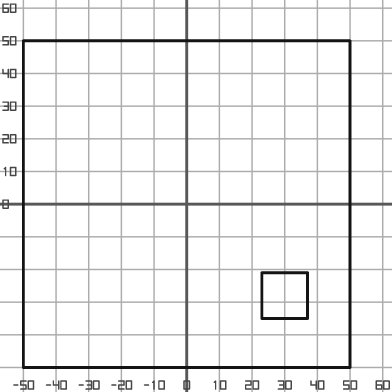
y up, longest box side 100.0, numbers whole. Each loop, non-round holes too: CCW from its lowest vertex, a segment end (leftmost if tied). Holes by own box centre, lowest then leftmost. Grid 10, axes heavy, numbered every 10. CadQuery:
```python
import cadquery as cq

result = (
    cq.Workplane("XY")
    .moveTo(-50.0, -50.0)
    .lineTo(50.0, -50.0)
    .lineTo(50.0, 50.0)
    .lineTo(-50.0, 50.0)
    .close()
    .moveTo(23.0, -35.0)
    .lineTo(37.0, -35.0)
    .lineTo(37.0, -21.0)
    .lineTo(23.0, -21.0)
    .close()
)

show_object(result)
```